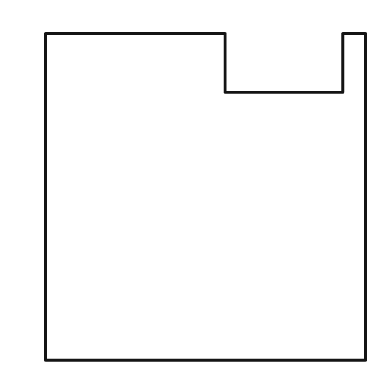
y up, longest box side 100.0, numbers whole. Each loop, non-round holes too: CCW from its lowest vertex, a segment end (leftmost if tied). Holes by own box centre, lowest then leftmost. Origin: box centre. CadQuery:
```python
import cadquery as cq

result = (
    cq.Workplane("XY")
    .moveTo(-49.0, -50.0)
    .lineTo(49.0, -50.0)
    .lineTo(49.0, 50.0)
    .lineTo(42.0, 50.0)
    .lineTo(42.0, 32.0)
    .lineTo(6.0, 32.0)
    .lineTo(6.0, 50.0)
    .lineTo(-49.0, 50.0)
    .close()
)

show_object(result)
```